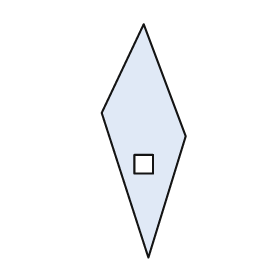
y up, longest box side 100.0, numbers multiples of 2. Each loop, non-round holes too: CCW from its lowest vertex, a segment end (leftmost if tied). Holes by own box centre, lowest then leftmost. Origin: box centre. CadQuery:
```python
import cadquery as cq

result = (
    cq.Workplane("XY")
    .moveTo(2.0, -50.0)
    .lineTo(18.0, 2.0)
    .lineTo(0.0, 50.0)
    .lineTo(-18.0, 12.0)
    .close()
    .moveTo(-4.0, -14.0)
    .lineTo(4.0, -14.0)
    .lineTo(4.0, -6.0)
    .lineTo(-4.0, -6.0)
    .close()
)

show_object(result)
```